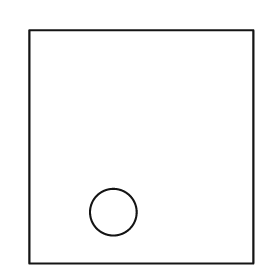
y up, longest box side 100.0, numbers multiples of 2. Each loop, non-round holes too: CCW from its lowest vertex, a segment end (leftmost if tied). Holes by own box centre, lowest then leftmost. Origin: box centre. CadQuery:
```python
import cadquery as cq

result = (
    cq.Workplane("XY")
    .moveTo(-48.0, -50.0)
    .lineTo(48.0, -50.0)
    .lineTo(48.0, 50.0)
    .lineTo(-48.0, 50.0)
    .close()
    .moveTo(-12.0, -28.0)
    .circle(10.0)
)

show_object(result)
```